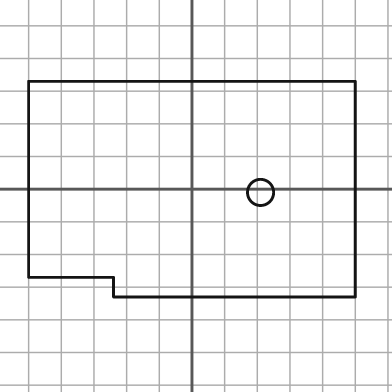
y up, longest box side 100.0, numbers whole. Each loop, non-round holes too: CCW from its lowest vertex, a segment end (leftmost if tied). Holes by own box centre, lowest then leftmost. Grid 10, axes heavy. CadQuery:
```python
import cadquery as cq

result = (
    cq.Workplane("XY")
    .moveTo(-24.0, -33.0)
    .lineTo(50.0, -33.0)
    .lineTo(50.0, 33.0)
    .lineTo(-50.0, 33.0)
    .lineTo(-50.0, -27.0)
    .lineTo(-24.0, -27.0)
    .close()
    .moveTo(21.0, -1.0)
    .circle(4.0)
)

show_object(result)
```